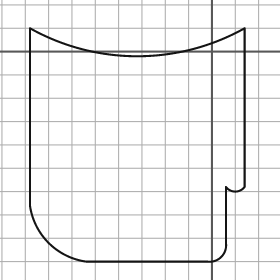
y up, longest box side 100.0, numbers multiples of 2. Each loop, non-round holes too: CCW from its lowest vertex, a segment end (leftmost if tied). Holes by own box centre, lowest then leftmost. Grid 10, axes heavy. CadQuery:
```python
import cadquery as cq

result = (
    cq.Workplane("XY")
    .moveTo(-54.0, -90.0)
    .lineTo(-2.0, -90.0)
    .threePointArc((4.0, -88.0), (6.0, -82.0))
    .lineTo(6.0, -58.0)
    .threePointArc((10.0, -60.0), (14.0, -58.0))
    .lineTo(14.0, 10.0)
    .threePointArc((-32.0, -2.0), (-78.0, 10.0))
    .lineTo(-78.0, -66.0)
    .threePointArc((-70.0, -82.0), (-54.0, -90.0))
    .close()
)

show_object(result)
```